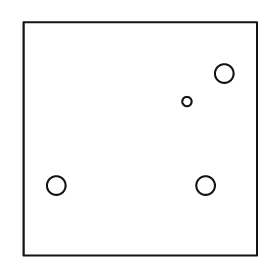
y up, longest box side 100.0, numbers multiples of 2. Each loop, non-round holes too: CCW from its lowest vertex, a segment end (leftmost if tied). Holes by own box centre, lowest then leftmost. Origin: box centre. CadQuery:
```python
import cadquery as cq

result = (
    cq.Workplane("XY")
    .moveTo(-50.0, -50.0)
    .lineTo(50.0, -50.0)
    .lineTo(50.0, 50.0)
    .lineTo(-50.0, 50.0)
    .close()
    .moveTo(-36.0, -20.0)
    .circle(4.0)
    .moveTo(28.0, -20.0)
    .circle(4.0)
    .moveTo(20.0, 16.0)
    .circle(2.0)
    .moveTo(36.0, 28.0)
    .circle(4.0)
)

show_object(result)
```